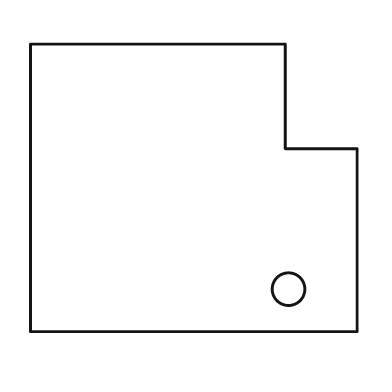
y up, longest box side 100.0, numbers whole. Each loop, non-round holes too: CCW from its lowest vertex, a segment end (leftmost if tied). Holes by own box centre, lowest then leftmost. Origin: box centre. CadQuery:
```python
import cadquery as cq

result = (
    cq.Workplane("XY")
    .moveTo(-50.0, -44.0)
    .lineTo(50.0, -44.0)
    .lineTo(50.0, 12.0)
    .lineTo(28.0, 12.0)
    .lineTo(28.0, 44.0)
    .lineTo(-50.0, 44.0)
    .close()
    .moveTo(29.0, -31.0)
    .circle(5.0)
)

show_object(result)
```